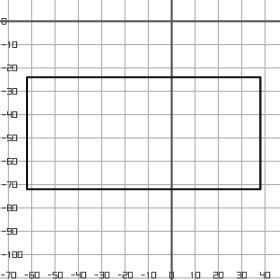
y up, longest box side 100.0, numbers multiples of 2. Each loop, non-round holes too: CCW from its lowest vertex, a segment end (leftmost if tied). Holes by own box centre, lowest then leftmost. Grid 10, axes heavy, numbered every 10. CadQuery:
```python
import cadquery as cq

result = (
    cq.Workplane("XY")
    .moveTo(-62.0, -72.0)
    .lineTo(38.0, -72.0)
    .lineTo(38.0, -24.0)
    .lineTo(-62.0, -24.0)
    .close()
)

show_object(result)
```